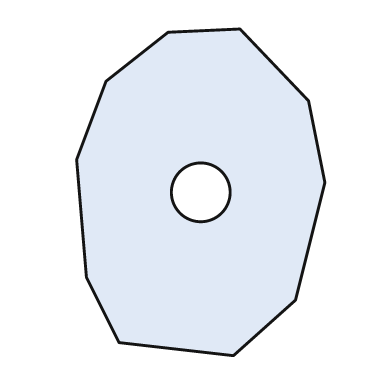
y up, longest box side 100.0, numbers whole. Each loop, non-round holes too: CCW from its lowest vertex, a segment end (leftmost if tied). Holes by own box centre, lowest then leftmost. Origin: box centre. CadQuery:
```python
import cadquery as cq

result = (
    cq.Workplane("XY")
    .moveTo(10.0, -50.0)
    .lineTo(29.0, -33.0)
    .lineTo(38.0, 3.0)
    .lineTo(33.0, 28.0)
    .lineTo(12.0, 50.0)
    .lineTo(-10.0, 49.0)
    .lineTo(-29.0, 34.0)
    .lineTo(-38.0, 10.0)
    .lineTo(-35.0, -26.0)
    .lineTo(-25.0, -46.0)
    .close()
    .moveTo(0.0, 0.0)
    .circle(9.0)
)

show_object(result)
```